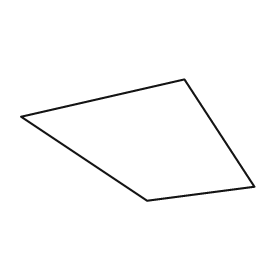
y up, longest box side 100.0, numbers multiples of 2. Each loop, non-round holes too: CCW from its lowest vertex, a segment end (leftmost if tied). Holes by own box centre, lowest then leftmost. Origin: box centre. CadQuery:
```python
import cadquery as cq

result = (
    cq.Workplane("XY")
    .moveTo(4.0, -26.0)
    .lineTo(50.0, -20.0)
    .lineTo(20.0, 26.0)
    .lineTo(-50.0, 10.0)
    .close()
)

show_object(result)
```